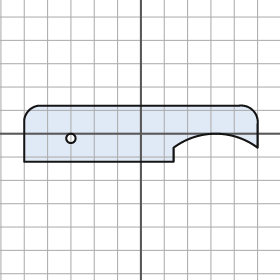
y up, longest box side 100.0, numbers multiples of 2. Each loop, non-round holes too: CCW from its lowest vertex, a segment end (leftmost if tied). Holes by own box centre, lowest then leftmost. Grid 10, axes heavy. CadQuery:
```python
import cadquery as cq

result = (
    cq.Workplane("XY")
    .moveTo(-50.0, -12.0)
    .lineTo(14.0, -12.0)
    .lineTo(14.0, -6.0)
    .threePointArc((32.0, 0.0), (50.0, -6.0))
    .lineTo(50.0, 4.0)
    .threePointArc((48.0, 10.0), (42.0, 12.0))
    .lineTo(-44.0, 12.0)
    .threePointArc((-48.0, 10.0), (-50.0, 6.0))
    .close()
    .moveTo(-30.0, -2.0)
    .circle(2.0)
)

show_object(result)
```